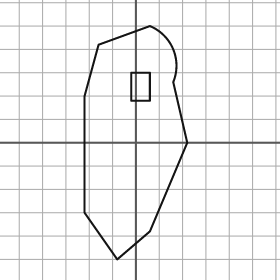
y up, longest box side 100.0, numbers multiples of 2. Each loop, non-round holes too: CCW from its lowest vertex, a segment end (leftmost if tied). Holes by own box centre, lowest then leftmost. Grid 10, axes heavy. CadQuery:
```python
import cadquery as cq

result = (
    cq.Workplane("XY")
    .moveTo(-8.0, -50.0)
    .lineTo(6.0, -38.0)
    .lineTo(22.0, 0.0)
    .lineTo(16.0, 26.0)
    .threePointArc((16.0, 40.0), (6.0, 50.0))
    .lineTo(-16.0, 42.0)
    .lineTo(-22.0, 20.0)
    .lineTo(-22.0, -30.0)
    .close()
    .moveTo(-2.0, 18.0)
    .lineTo(6.0, 18.0)
    .lineTo(6.0, 30.0)
    .lineTo(-2.0, 30.0)
    .close()
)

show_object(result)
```